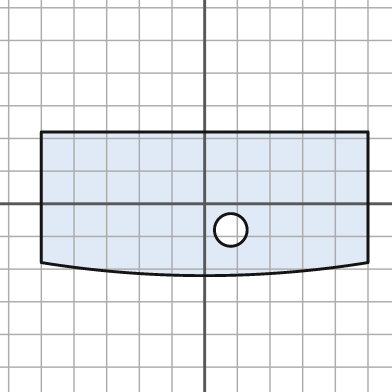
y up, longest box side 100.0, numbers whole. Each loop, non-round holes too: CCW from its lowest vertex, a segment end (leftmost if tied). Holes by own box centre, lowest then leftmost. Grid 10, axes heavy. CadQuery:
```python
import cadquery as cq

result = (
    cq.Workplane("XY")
    .moveTo(-50.0, -18.0)
    .threePointArc((0.0, -22.0), (50.0, -18.0))
    .lineTo(50.0, 22.0)
    .lineTo(-50.0, 22.0)
    .close()
    .moveTo(8.0, -8.0)
    .circle(5.0)
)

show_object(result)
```